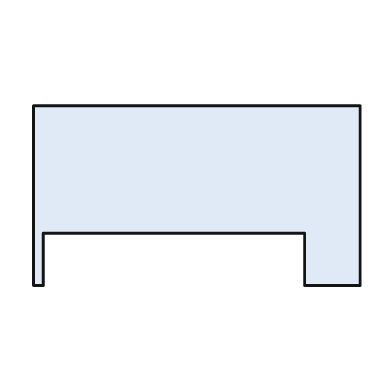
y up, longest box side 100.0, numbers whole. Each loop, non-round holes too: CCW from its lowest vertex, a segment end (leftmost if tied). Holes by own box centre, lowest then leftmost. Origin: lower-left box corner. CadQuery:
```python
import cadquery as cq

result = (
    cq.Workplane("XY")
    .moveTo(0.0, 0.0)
    .lineTo(3.0, 0.0)
    .lineTo(3.0, 16.0)
    .lineTo(83.0, 16.0)
    .lineTo(83.0, 0.0)
    .lineTo(100.0, 0.0)
    .lineTo(100.0, 55.0)
    .lineTo(0.0, 55.0)
    .close()
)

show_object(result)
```